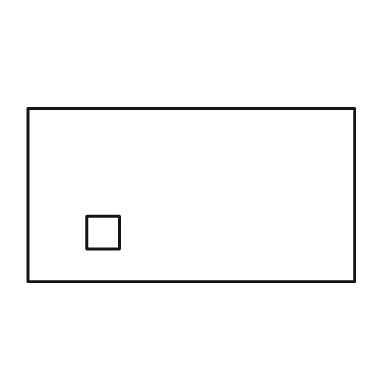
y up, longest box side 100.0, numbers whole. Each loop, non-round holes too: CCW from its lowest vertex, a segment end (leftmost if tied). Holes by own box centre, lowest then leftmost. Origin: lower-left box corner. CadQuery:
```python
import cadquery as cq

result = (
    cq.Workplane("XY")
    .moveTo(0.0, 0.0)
    .lineTo(100.0, 0.0)
    .lineTo(100.0, 53.0)
    .lineTo(0.0, 53.0)
    .close()
    .moveTo(18.0, 10.0)
    .lineTo(28.0, 10.0)
    .lineTo(28.0, 20.0)
    .lineTo(18.0, 20.0)
    .close()
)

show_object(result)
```